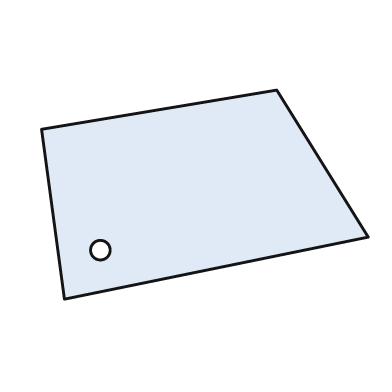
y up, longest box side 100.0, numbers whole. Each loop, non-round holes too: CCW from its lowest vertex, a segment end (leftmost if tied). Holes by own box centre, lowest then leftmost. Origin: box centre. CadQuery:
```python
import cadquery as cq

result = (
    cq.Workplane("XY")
    .moveTo(-43.0, -32.0)
    .lineTo(50.0, -13.0)
    .lineTo(22.0, 32.0)
    .lineTo(-50.0, 20.0)
    .close()
    .moveTo(-32.0, -17.0)
    .circle(3.0)
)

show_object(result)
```